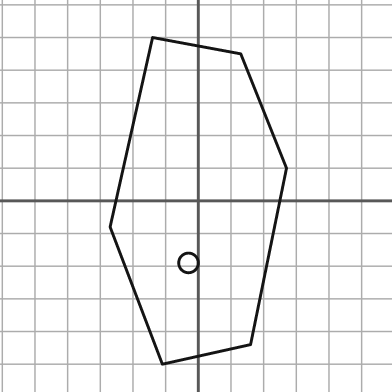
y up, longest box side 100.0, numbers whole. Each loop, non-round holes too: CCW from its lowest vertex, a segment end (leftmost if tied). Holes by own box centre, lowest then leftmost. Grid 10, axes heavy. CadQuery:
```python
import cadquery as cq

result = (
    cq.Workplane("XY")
    .moveTo(-11.0, -50.0)
    .lineTo(16.0, -44.0)
    .lineTo(27.0, 10.0)
    .lineTo(13.0, 45.0)
    .lineTo(-14.0, 50.0)
    .lineTo(-27.0, -8.0)
    .close()
    .moveTo(-3.0, -19.0)
    .circle(3.0)
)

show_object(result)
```